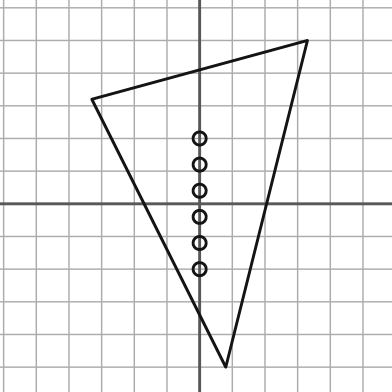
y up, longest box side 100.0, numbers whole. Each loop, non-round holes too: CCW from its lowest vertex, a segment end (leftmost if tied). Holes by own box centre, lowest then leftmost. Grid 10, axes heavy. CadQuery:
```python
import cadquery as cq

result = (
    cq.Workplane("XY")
    .moveTo(8.0, -50.0)
    .lineTo(33.0, 50.0)
    .lineTo(-33.0, 32.0)
    .close()
    .moveTo(0.0, -20.0)
    .circle(2.0)
    .moveTo(0.0, -12.0)
    .circle(2.0)
    .moveTo(0.0, -4.0)
    .circle(2.0)
    .moveTo(0.0, 4.0)
    .circle(2.0)
    .moveTo(0.0, 12.0)
    .circle(2.0)
    .moveTo(0.0, 20.0)
    .circle(2.0)
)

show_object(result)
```